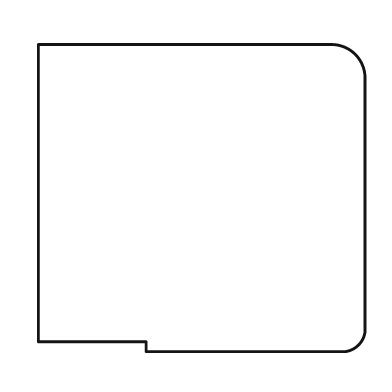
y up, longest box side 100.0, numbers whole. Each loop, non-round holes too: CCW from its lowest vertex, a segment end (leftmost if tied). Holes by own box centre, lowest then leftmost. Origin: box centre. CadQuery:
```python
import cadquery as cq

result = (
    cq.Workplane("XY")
    .moveTo(-17.0, -47.0)
    .lineTo(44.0, -47.0)
    .threePointArc((48.0, -45.0), (50.0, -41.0))
    .lineTo(50.0, 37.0)
    .threePointArc((47.0, 44.0), (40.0, 47.0))
    .lineTo(-50.0, 47.0)
    .lineTo(-50.0, -44.0)
    .lineTo(-17.0, -44.0)
    .close()
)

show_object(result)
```